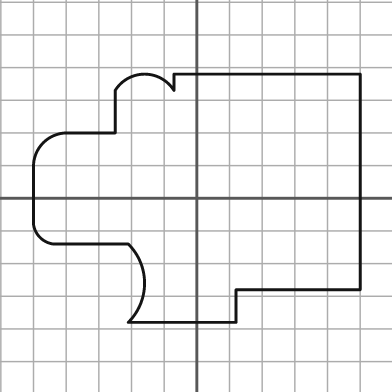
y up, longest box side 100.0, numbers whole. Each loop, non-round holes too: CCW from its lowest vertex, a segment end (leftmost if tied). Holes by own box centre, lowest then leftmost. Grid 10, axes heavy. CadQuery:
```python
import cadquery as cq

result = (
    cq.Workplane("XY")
    .moveTo(-21.0, -38.0)
    .lineTo(12.0, -38.0)
    .lineTo(12.0, -28.0)
    .lineTo(50.0, -28.0)
    .lineTo(50.0, 38.0)
    .lineTo(-7.0, 38.0)
    .lineTo(-7.0, 33.0)
    .threePointArc((-16.0, 38.0), (-25.0, 33.0))
    .lineTo(-25.0, 20.0)
    .lineTo(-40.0, 20.0)
    .threePointArc((-47.0, 17.0), (-50.0, 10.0))
    .lineTo(-50.0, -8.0)
    .threePointArc((-48.0, -12.0), (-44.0, -14.0))
    .lineTo(-21.0, -14.0)
    .threePointArc((-16.0, -26.0), (-21.0, -38.0))
    .close()
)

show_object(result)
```